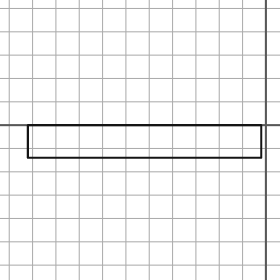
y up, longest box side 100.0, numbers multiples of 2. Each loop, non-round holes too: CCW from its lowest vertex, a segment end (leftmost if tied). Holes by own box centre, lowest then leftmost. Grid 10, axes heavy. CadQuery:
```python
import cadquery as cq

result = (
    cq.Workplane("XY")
    .moveTo(-102.0, -14.0)
    .lineTo(-2.0, -14.0)
    .lineTo(-2.0, 0.0)
    .lineTo(-102.0, 0.0)
    .close()
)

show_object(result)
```